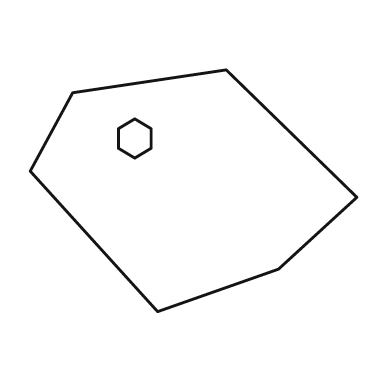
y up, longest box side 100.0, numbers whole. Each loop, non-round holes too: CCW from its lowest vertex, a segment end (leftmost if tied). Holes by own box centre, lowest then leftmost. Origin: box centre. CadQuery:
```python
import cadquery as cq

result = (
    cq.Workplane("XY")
    .moveTo(-11.0, -37.0)
    .lineTo(26.0, -24.0)
    .lineTo(50.0, -2.0)
    .lineTo(10.0, 37.0)
    .lineTo(-37.0, 30.0)
    .lineTo(-50.0, 6.0)
    .close()
    .moveTo(-18.0, 10.0)
    .lineTo(-13.0, 13.0)
    .lineTo(-13.0, 19.0)
    .lineTo(-18.0, 22.0)
    .lineTo(-23.0, 19.0)
    .lineTo(-23.0, 13.0)
    .close()
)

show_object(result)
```